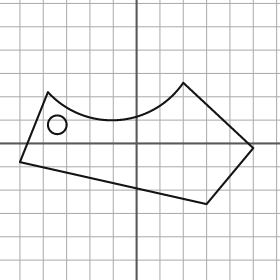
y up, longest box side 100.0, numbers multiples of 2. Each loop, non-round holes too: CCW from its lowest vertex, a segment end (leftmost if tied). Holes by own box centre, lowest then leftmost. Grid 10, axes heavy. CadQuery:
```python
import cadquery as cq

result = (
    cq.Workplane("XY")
    .moveTo(30.0, -26.0)
    .lineTo(50.0, -2.0)
    .lineTo(20.0, 26.0)
    .threePointArc((-8.0, 10.0), (-38.0, 22.0))
    .lineTo(-50.0, -8.0)
    .close()
    .moveTo(-34.0, 8.0)
    .circle(4.0)
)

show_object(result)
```